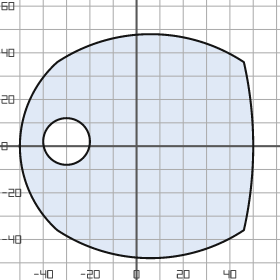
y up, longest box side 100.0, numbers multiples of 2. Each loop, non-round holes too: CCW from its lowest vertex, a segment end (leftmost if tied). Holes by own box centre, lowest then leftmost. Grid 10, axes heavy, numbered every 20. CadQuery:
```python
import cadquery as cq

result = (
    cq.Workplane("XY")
    .moveTo(-34.0, -36.0)
    .threePointArc((6.0, -48.0), (46.0, -36.0))
    .threePointArc((50.0, 0.0), (46.0, 36.0))
    .threePointArc((6.0, 48.0), (-34.0, 36.0))
    .threePointArc((-50.0, 0.0), (-34.0, -36.0))
    .close()
    .moveTo(-30.0, 2.0)
    .circle(10.0)
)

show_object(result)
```